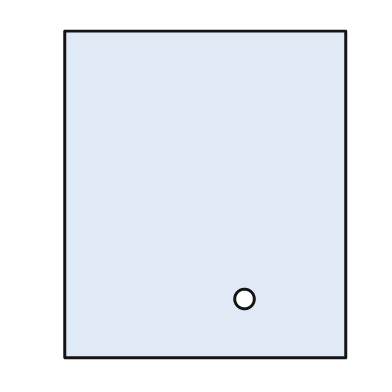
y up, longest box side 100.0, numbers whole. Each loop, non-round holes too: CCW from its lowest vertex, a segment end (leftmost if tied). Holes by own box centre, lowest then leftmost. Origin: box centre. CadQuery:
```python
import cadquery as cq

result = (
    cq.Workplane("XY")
    .moveTo(-43.0, -50.0)
    .lineTo(43.0, -50.0)
    .lineTo(43.0, 50.0)
    .lineTo(-43.0, 50.0)
    .close()
    .moveTo(12.0, -32.0)
    .circle(3.0)
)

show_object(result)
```